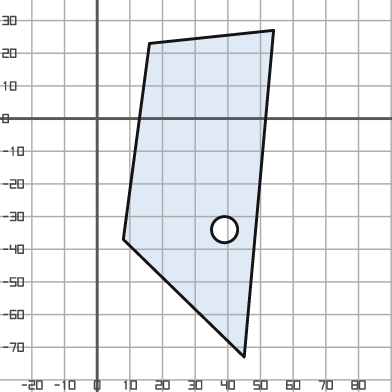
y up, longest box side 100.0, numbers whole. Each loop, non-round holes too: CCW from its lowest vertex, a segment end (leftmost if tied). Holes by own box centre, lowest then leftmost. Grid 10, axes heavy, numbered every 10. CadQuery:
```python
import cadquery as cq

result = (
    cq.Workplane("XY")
    .moveTo(45.0, -73.0)
    .lineTo(54.0, 27.0)
    .lineTo(16.0, 23.0)
    .lineTo(8.0, -37.0)
    .close()
    .moveTo(39.0, -34.0)
    .circle(4.0)
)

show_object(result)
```